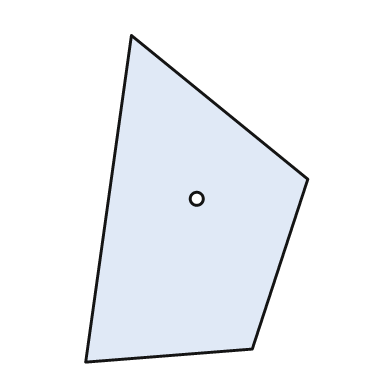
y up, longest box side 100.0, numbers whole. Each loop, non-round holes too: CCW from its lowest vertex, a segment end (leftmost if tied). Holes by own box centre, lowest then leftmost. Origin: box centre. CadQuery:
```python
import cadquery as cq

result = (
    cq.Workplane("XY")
    .moveTo(-34.0, -50.0)
    .lineTo(17.0, -46.0)
    .lineTo(34.0, 6.0)
    .lineTo(-20.0, 50.0)
    .close()
    .moveTo(0.0, 0.0)
    .circle(2.0)
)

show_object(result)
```